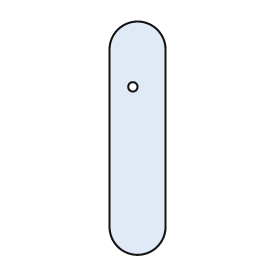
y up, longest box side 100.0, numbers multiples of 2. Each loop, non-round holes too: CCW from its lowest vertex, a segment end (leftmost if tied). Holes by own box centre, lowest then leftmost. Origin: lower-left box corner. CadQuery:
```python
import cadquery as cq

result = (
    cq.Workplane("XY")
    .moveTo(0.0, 12.0)
    .threePointArc((12.0, 0.0), (24.0, 12.0))
    .lineTo(24.0, 88.0)
    .threePointArc((12.0, 100.0), (0.0, 88.0))
    .close()
    .moveTo(10.0, 72.0)
    .circle(2.0)
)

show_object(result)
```